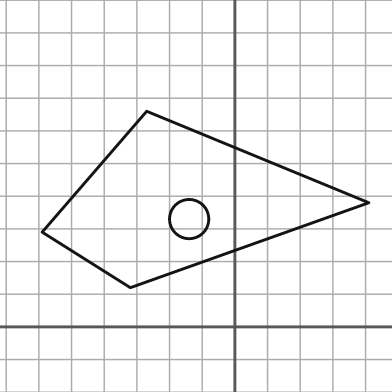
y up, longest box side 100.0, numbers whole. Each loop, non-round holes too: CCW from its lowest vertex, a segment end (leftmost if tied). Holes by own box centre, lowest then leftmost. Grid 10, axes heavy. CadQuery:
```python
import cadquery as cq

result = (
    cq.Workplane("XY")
    .moveTo(-32.0, 12.0)
    .lineTo(41.0, 38.0)
    .lineTo(-27.0, 66.0)
    .lineTo(-59.0, 29.0)
    .close()
    .moveTo(-14.0, 33.0)
    .circle(6.0)
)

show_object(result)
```